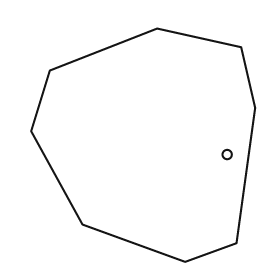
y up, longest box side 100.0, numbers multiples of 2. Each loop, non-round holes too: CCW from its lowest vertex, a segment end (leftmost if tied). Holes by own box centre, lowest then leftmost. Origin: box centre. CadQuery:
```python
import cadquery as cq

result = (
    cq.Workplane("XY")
    .moveTo(18.0, -50.0)
    .lineTo(40.0, -42.0)
    .lineTo(48.0, 16.0)
    .lineTo(42.0, 42.0)
    .lineTo(6.0, 50.0)
    .lineTo(-40.0, 32.0)
    .lineTo(-48.0, 6.0)
    .lineTo(-26.0, -34.0)
    .close()
    .moveTo(36.0, -4.0)
    .circle(2.0)
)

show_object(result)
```